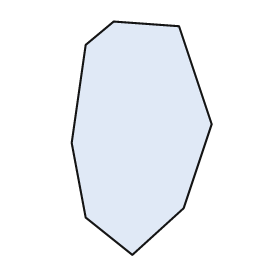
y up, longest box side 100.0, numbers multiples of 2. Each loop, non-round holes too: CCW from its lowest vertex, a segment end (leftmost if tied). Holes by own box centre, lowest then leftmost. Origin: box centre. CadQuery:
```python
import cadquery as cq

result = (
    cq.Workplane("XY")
    .moveTo(-4.0, -50.0)
    .lineTo(18.0, -30.0)
    .lineTo(30.0, 6.0)
    .lineTo(16.0, 48.0)
    .lineTo(-12.0, 50.0)
    .lineTo(-24.0, 40.0)
    .lineTo(-30.0, -2.0)
    .lineTo(-24.0, -34.0)
    .close()
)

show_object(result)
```